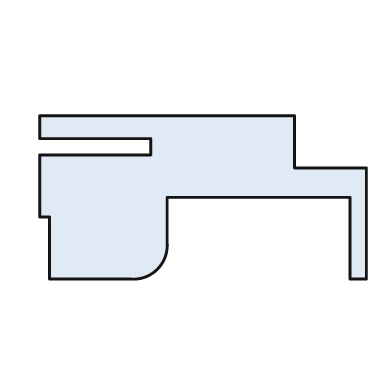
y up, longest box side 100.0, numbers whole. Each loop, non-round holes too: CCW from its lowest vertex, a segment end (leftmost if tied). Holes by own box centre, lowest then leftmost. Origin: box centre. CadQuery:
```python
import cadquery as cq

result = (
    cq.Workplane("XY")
    .moveTo(-47.0, -25.0)
    .lineTo(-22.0, -25.0)
    .threePointArc((-14.0, -22.0), (-11.0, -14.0))
    .lineTo(-11.0, 0.0)
    .lineTo(45.0, 0.0)
    .lineTo(45.0, -25.0)
    .lineTo(50.0, -25.0)
    .lineTo(50.0, 9.0)
    .lineTo(28.0, 9.0)
    .lineTo(28.0, 25.0)
    .lineTo(-50.0, 25.0)
    .lineTo(-50.0, 18.0)
    .lineTo(-16.0, 18.0)
    .lineTo(-16.0, 13.0)
    .lineTo(-50.0, 13.0)
    .lineTo(-50.0, -6.0)
    .lineTo(-47.0, -6.0)
    .close()
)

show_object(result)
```